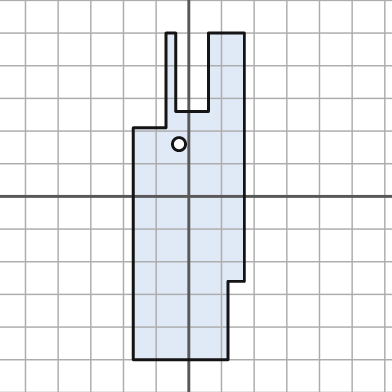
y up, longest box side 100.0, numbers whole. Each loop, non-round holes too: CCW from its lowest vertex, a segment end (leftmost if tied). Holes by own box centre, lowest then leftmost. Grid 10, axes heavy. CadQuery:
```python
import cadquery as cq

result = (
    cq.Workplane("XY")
    .moveTo(-17.0, -50.0)
    .lineTo(12.0, -50.0)
    .lineTo(12.0, -26.0)
    .lineTo(17.0, -26.0)
    .lineTo(17.0, 50.0)
    .lineTo(6.0, 50.0)
    .lineTo(6.0, 26.0)
    .lineTo(-4.0, 26.0)
    .lineTo(-4.0, 50.0)
    .lineTo(-7.0, 50.0)
    .lineTo(-7.0, 21.0)
    .lineTo(-17.0, 21.0)
    .close()
    .moveTo(-3.0, 16.0)
    .circle(2.0)
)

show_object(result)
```